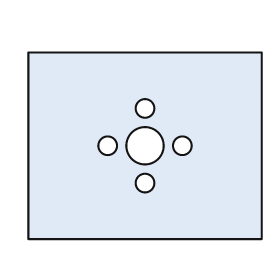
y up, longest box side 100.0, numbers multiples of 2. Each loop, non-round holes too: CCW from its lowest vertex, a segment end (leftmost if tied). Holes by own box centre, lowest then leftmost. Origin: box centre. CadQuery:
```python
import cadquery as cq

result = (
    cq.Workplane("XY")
    .moveTo(-50.0, -40.0)
    .lineTo(50.0, -40.0)
    .lineTo(50.0, 40.0)
    .lineTo(-50.0, 40.0)
    .close()
    .moveTo(0.0, -16.0)
    .circle(4.0)
    .moveTo(-16.0, 0.0)
    .circle(4.0)
    .moveTo(0.0, 0.0)
    .circle(8.0)
    .moveTo(16.0, 0.0)
    .circle(4.0)
    .moveTo(0.0, 16.0)
    .circle(4.0)
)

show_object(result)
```